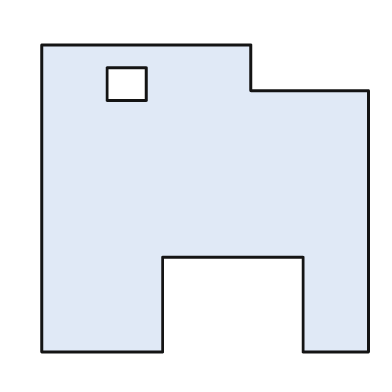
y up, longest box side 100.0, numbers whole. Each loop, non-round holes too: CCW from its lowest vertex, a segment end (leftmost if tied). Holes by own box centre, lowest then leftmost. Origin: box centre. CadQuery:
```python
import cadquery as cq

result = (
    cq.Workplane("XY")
    .moveTo(-50.0, -47.0)
    .lineTo(-13.0, -47.0)
    .lineTo(-13.0, -18.0)
    .lineTo(30.0, -18.0)
    .lineTo(30.0, -47.0)
    .lineTo(50.0, -47.0)
    .lineTo(50.0, 33.0)
    .lineTo(14.0, 33.0)
    .lineTo(14.0, 47.0)
    .lineTo(-50.0, 47.0)
    .close()
    .moveTo(-30.0, 30.0)
    .lineTo(-18.0, 30.0)
    .lineTo(-18.0, 40.0)
    .lineTo(-30.0, 40.0)
    .close()
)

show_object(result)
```